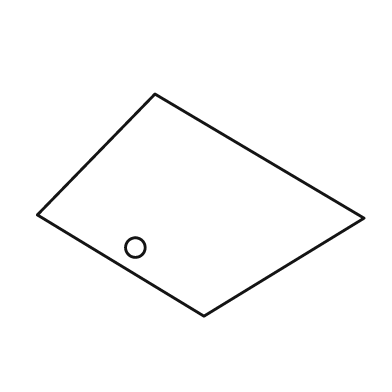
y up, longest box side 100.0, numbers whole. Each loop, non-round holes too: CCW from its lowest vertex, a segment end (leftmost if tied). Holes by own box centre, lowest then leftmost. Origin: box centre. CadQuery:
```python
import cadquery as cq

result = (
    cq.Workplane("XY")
    .moveTo(1.0, -34.0)
    .lineTo(50.0, -4.0)
    .lineTo(-14.0, 34.0)
    .lineTo(-50.0, -3.0)
    .close()
    .moveTo(-20.0, -13.0)
    .circle(3.0)
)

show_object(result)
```